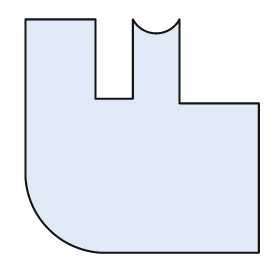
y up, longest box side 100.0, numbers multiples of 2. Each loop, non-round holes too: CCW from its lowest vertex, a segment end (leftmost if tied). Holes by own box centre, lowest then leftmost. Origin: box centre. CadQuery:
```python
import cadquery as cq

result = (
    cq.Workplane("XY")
    .moveTo(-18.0, -50.0)
    .lineTo(50.0, -50.0)
    .lineTo(50.0, 14.0)
    .lineTo(16.0, 14.0)
    .lineTo(16.0, 50.0)
    .threePointArc((6.0, 44.0), (-4.0, 50.0))
    .lineTo(-4.0, 16.0)
    .lineTo(-20.0, 16.0)
    .lineTo(-20.0, 50.0)
    .lineTo(-50.0, 50.0)
    .lineTo(-50.0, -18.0)
    .threePointArc((-40.0, -40.0), (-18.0, -50.0))
    .close()
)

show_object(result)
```